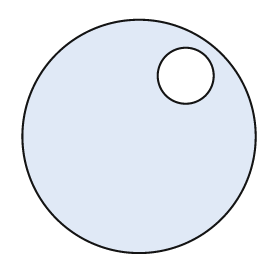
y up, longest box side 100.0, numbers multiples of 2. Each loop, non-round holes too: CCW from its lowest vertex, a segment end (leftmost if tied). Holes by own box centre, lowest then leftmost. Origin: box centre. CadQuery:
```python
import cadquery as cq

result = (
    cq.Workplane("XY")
    .moveTo(0.0, 0.0)
    .circle(50.0)
    .moveTo(20.0, 26.0)
    .circle(12.0)
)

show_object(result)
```